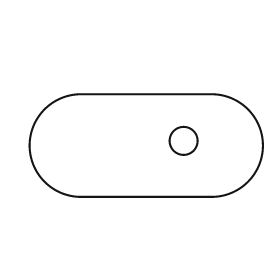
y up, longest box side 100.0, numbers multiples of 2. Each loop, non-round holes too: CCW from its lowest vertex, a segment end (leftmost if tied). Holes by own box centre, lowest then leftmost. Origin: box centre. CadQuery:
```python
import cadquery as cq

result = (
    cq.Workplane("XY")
    .moveTo(-28.0, -22.0)
    .lineTo(28.0, -22.0)
    .threePointArc((50.0, 0.0), (28.0, 22.0))
    .lineTo(-28.0, 22.0)
    .threePointArc((-50.0, 0.0), (-28.0, -22.0))
    .close()
    .moveTo(16.0, 2.0)
    .circle(6.0)
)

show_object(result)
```